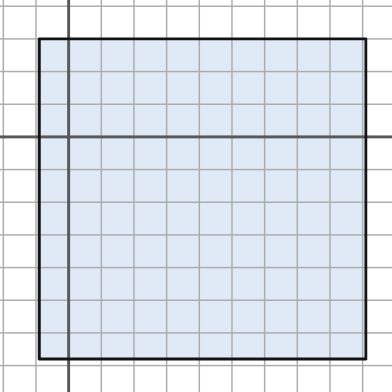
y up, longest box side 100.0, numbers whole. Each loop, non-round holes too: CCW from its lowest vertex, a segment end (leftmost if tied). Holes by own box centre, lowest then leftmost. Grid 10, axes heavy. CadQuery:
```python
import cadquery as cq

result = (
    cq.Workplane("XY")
    .moveTo(-9.0, -68.0)
    .lineTo(91.0, -68.0)
    .lineTo(91.0, 30.0)
    .lineTo(-9.0, 30.0)
    .close()
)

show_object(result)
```